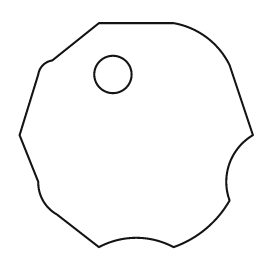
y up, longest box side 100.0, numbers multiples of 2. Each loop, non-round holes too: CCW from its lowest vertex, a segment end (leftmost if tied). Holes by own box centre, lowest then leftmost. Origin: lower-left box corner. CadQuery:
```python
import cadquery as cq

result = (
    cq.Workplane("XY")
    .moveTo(34.0, 0.0)
    .threePointArc((50.0, 4.0), (66.0, 0.0))
    .threePointArc((80.0, 8.0), (90.0, 20.0))
    .threePointArc((90.0, 36.0), (100.0, 48.0))
    .lineTo(90.0, 78.0)
    .threePointArc((80.0, 90.0), (66.0, 96.0))
    .lineTo(34.0, 96.0)
    .lineTo(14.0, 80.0)
    .threePointArc((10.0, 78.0), (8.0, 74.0))
    .lineTo(0.0, 48.0)
    .lineTo(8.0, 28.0)
    .threePointArc((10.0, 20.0), (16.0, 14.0))
    .close()
    .moveTo(40.0, 74.0)
    .circle(8.0)
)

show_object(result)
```